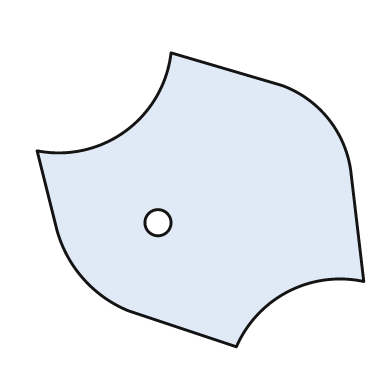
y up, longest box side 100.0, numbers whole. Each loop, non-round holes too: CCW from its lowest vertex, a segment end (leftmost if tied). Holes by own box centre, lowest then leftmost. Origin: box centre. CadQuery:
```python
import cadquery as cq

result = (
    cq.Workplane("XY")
    .moveTo(11.0, -45.0)
    .threePointArc((27.0, -28.0), (50.0, -25.0))
    .lineTo(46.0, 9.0)
    .threePointArc((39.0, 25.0), (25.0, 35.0))
    .lineTo(-9.0, 45.0)
    .threePointArc((-23.0, 21.0), (-50.0, 15.0))
    .lineTo(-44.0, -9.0)
    .threePointArc((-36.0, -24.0), (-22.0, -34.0))
    .close()
    .moveTo(-13.0, -7.0)
    .circle(4.0)
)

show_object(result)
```